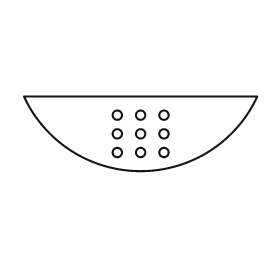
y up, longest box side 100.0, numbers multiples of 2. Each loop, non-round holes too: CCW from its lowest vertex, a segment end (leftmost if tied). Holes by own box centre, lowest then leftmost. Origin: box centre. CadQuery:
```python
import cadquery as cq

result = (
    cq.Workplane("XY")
    .moveTo(-50.0, 16.0)
    .threePointArc((0.0, -16.0), (50.0, 16.0))
    .close()
    .moveTo(-10.0, -8.0)
    .circle(2.0)
    .moveTo(0.0, -8.0)
    .circle(2.0)
    .moveTo(10.0, -8.0)
    .circle(2.0)
    .moveTo(-10.0, 0.0)
    .circle(2.0)
    .moveTo(0.0, 0.0)
    .circle(2.0)
    .moveTo(10.0, 0.0)
    .circle(2.0)
    .moveTo(-10.0, 8.0)
    .circle(2.0)
    .moveTo(0.0, 8.0)
    .circle(2.0)
    .moveTo(10.0, 8.0)
    .circle(2.0)
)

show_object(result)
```